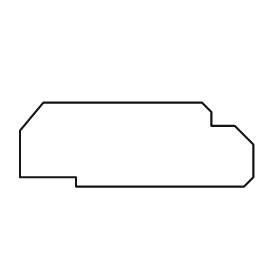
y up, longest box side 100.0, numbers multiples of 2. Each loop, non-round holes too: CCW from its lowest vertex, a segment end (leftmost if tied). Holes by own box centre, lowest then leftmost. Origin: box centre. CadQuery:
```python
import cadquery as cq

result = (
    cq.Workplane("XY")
    .moveTo(-26.0, -18.0)
    .lineTo(46.0, -18.0)
    .lineTo(50.0, -14.0)
    .lineTo(50.0, 0.0)
    .lineTo(42.0, 8.0)
    .lineTo(32.0, 8.0)
    .lineTo(32.0, 14.0)
    .lineTo(28.0, 18.0)
    .lineTo(-40.0, 18.0)
    .lineTo(-50.0, 6.0)
    .lineTo(-50.0, -14.0)
    .lineTo(-26.0, -14.0)
    .close()
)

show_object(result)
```